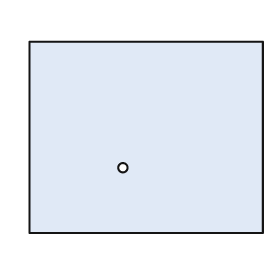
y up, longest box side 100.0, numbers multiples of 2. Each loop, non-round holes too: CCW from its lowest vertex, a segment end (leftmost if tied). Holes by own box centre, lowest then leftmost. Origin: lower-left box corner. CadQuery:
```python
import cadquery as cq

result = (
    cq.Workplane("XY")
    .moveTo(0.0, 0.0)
    .lineTo(100.0, 0.0)
    .lineTo(100.0, 82.0)
    .lineTo(0.0, 82.0)
    .close()
    .moveTo(40.0, 28.0)
    .circle(2.0)
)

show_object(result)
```